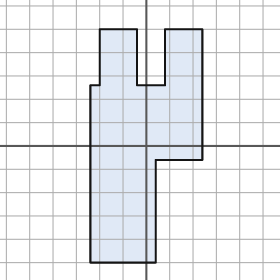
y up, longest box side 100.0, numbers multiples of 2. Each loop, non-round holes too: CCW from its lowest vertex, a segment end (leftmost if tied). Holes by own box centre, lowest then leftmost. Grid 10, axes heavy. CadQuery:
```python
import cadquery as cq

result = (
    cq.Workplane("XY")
    .moveTo(-24.0, -50.0)
    .lineTo(4.0, -50.0)
    .lineTo(4.0, -6.0)
    .lineTo(24.0, -6.0)
    .lineTo(24.0, 50.0)
    .lineTo(8.0, 50.0)
    .lineTo(8.0, 26.0)
    .lineTo(-4.0, 26.0)
    .lineTo(-4.0, 50.0)
    .lineTo(-20.0, 50.0)
    .lineTo(-20.0, 26.0)
    .lineTo(-24.0, 26.0)
    .close()
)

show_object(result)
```